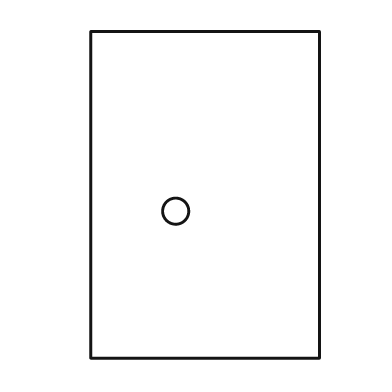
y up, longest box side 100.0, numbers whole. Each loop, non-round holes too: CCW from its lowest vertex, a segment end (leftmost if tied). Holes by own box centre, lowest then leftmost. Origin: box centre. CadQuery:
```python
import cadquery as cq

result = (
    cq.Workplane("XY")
    .moveTo(-35.0, -50.0)
    .lineTo(35.0, -50.0)
    .lineTo(35.0, 50.0)
    .lineTo(-35.0, 50.0)
    .close()
    .moveTo(-9.0, -5.0)
    .circle(4.0)
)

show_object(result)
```